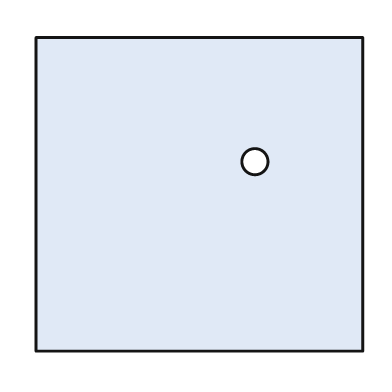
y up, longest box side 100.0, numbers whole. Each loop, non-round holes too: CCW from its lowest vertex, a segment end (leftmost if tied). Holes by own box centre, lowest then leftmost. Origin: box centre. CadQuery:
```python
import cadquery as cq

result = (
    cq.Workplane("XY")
    .moveTo(-50.0, -48.0)
    .lineTo(50.0, -48.0)
    .lineTo(50.0, 48.0)
    .lineTo(-50.0, 48.0)
    .close()
    .moveTo(17.0, 10.0)
    .circle(4.0)
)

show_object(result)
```